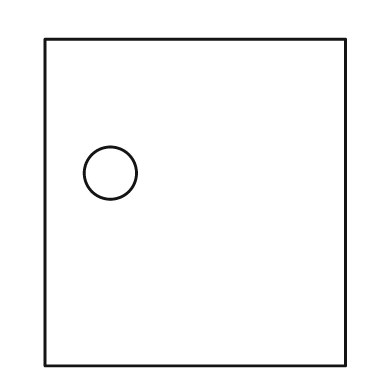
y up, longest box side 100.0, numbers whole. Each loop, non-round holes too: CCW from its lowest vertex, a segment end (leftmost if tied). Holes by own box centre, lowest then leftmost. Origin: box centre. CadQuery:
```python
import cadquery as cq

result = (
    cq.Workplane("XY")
    .moveTo(-46.0, -50.0)
    .lineTo(46.0, -50.0)
    .lineTo(46.0, 50.0)
    .lineTo(-46.0, 50.0)
    .close()
    .moveTo(-26.0, 9.0)
    .circle(8.0)
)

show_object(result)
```